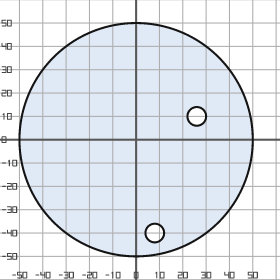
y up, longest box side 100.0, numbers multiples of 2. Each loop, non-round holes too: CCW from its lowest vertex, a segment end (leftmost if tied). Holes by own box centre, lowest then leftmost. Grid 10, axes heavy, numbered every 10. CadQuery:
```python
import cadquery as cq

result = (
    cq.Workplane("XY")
    .moveTo(0.0, 0.0)
    .circle(50.0)
    .moveTo(8.0, -40.0)
    .circle(4.0)
    .moveTo(26.0, 10.0)
    .circle(4.0)
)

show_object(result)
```